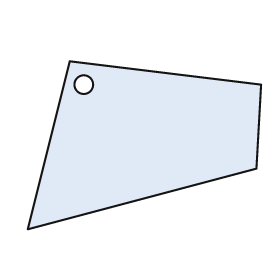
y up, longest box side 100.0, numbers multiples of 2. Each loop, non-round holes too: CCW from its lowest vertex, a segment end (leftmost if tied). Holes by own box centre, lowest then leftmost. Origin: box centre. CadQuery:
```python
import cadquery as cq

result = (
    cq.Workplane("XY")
    .moveTo(-50.0, -36.0)
    .lineTo(48.0, -10.0)
    .lineTo(50.0, 26.0)
    .lineTo(-32.0, 36.0)
    .close()
    .moveTo(-26.0, 26.0)
    .circle(4.0)
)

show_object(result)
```